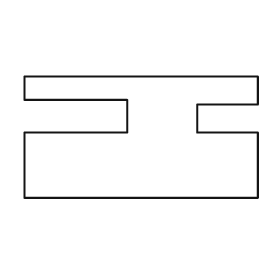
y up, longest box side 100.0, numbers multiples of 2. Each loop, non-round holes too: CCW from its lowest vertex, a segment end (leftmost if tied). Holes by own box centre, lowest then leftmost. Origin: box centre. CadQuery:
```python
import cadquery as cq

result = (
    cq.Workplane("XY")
    .moveTo(-50.0, -26.0)
    .lineTo(50.0, -26.0)
    .lineTo(50.0, 2.0)
    .lineTo(24.0, 2.0)
    .lineTo(24.0, 14.0)
    .lineTo(50.0, 14.0)
    .lineTo(50.0, 26.0)
    .lineTo(-50.0, 26.0)
    .lineTo(-50.0, 16.0)
    .lineTo(-6.0, 16.0)
    .lineTo(-6.0, 2.0)
    .lineTo(-50.0, 2.0)
    .close()
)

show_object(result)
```